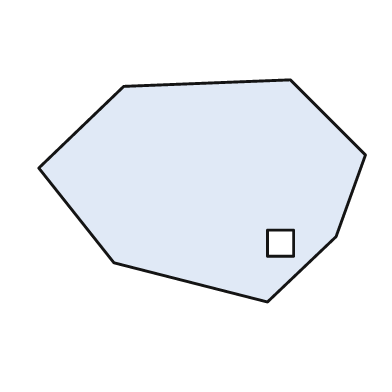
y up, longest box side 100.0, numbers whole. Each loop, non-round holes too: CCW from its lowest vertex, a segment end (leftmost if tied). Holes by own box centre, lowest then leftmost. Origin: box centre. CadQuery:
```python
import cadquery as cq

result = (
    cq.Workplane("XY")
    .moveTo(20.0, -34.0)
    .lineTo(41.0, -14.0)
    .lineTo(50.0, 11.0)
    .lineTo(27.0, 34.0)
    .lineTo(-24.0, 32.0)
    .lineTo(-50.0, 7.0)
    .lineTo(-27.0, -22.0)
    .close()
    .moveTo(20.0, -20.0)
    .lineTo(28.0, -20.0)
    .lineTo(28.0, -12.0)
    .lineTo(20.0, -12.0)
    .close()
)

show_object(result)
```